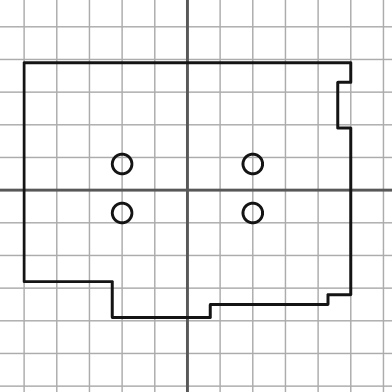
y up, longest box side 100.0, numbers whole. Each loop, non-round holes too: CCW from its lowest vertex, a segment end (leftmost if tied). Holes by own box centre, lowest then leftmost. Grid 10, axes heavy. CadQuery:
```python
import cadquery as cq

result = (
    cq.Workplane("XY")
    .moveTo(-23.0, -39.0)
    .lineTo(7.0, -39.0)
    .lineTo(7.0, -35.0)
    .lineTo(43.0, -35.0)
    .lineTo(43.0, -32.0)
    .lineTo(50.0, -32.0)
    .lineTo(50.0, 19.0)
    .lineTo(46.0, 19.0)
    .lineTo(46.0, 33.0)
    .lineTo(50.0, 33.0)
    .lineTo(50.0, 39.0)
    .lineTo(-50.0, 39.0)
    .lineTo(-50.0, -28.0)
    .lineTo(-23.0, -28.0)
    .close()
    .moveTo(-20.0, -7.0)
    .circle(3.0)
    .moveTo(20.0, -7.0)
    .circle(3.0)
    .moveTo(-20.0, 8.0)
    .circle(3.0)
    .moveTo(20.0, 8.0)
    .circle(3.0)
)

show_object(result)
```